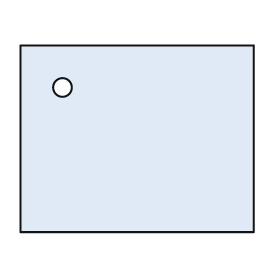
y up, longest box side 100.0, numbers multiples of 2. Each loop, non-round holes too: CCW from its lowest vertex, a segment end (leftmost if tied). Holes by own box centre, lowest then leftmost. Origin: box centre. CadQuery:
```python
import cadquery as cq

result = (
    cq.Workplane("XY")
    .moveTo(-50.0, -40.0)
    .lineTo(50.0, -40.0)
    .lineTo(50.0, 40.0)
    .lineTo(-50.0, 40.0)
    .close()
    .moveTo(-32.0, 22.0)
    .circle(4.0)
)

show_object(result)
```